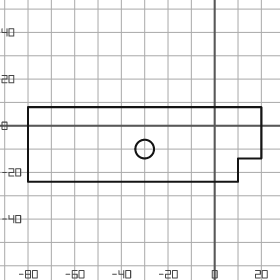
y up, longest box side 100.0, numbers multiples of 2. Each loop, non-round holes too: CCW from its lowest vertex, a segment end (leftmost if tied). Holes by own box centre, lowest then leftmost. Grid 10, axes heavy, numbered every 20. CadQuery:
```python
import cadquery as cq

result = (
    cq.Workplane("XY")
    .moveTo(-80.0, -24.0)
    .lineTo(10.0, -24.0)
    .lineTo(10.0, -14.0)
    .lineTo(20.0, -14.0)
    .lineTo(20.0, 8.0)
    .lineTo(-80.0, 8.0)
    .close()
    .moveTo(-30.0, -10.0)
    .circle(4.0)
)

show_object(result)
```